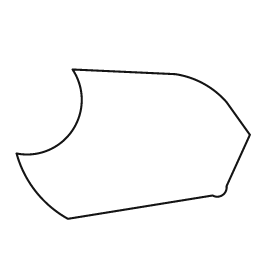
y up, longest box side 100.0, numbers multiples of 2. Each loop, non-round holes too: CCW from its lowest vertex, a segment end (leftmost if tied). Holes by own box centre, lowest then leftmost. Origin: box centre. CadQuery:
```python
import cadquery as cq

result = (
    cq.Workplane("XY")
    .moveTo(-28.0, -32.0)
    .lineTo(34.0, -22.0)
    .threePointArc((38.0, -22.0), (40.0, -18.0))
    .lineTo(50.0, 4.0)
    .lineTo(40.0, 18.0)
    .threePointArc((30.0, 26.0), (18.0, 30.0))
    .lineTo(-26.0, 32.0)
    .threePointArc((-26.0, 6.0), (-50.0, -4.0))
    .threePointArc((-42.0, -20.0), (-28.0, -32.0))
    .close()
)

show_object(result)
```